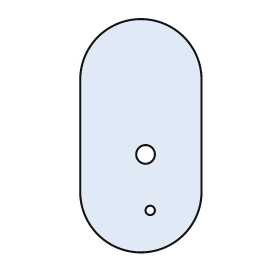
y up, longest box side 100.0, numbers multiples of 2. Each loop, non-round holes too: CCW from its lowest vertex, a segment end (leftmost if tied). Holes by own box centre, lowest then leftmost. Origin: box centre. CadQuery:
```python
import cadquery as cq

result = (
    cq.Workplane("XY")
    .moveTo(-26.0, -24.0)
    .threePointArc((0.0, -50.0), (26.0, -24.0))
    .lineTo(26.0, 24.0)
    .threePointArc((0.0, 50.0), (-26.0, 24.0))
    .close()
    .moveTo(4.0, -32.0)
    .circle(2.0)
    .moveTo(2.0, -8.0)
    .circle(4.0)
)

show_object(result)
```